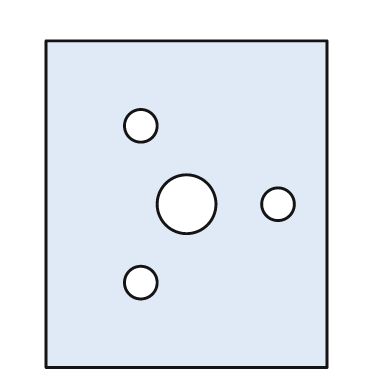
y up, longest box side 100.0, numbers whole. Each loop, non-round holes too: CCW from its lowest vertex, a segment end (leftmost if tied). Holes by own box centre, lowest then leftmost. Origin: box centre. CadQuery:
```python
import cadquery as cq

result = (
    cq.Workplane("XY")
    .moveTo(-43.0, -50.0)
    .lineTo(43.0, -50.0)
    .lineTo(43.0, 50.0)
    .lineTo(-43.0, 50.0)
    .close()
    .moveTo(-14.0, -24.0)
    .circle(5.0)
    .moveTo(0.0, 0.0)
    .circle(9.0)
    .moveTo(28.0, 0.0)
    .circle(5.0)
    .moveTo(-14.0, 24.0)
    .circle(5.0)
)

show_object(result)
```